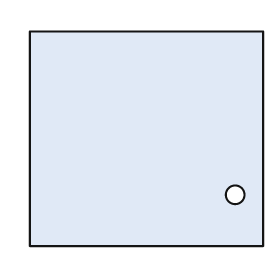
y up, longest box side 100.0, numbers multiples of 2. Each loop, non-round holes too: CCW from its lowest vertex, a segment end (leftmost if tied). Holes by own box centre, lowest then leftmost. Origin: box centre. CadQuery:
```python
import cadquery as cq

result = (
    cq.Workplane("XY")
    .moveTo(-50.0, -46.0)
    .lineTo(50.0, -46.0)
    .lineTo(50.0, 46.0)
    .lineTo(-50.0, 46.0)
    .close()
    .moveTo(38.0, -24.0)
    .circle(4.0)
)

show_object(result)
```